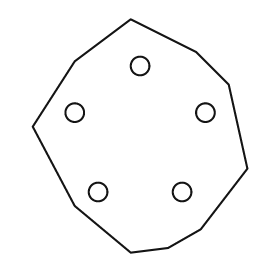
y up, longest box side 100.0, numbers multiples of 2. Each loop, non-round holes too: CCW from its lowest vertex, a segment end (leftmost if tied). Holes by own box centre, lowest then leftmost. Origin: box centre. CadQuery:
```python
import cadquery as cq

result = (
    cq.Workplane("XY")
    .moveTo(-4.0, -50.0)
    .lineTo(12.0, -48.0)
    .lineTo(26.0, -40.0)
    .lineTo(46.0, -14.0)
    .lineTo(38.0, 22.0)
    .lineTo(24.0, 36.0)
    .lineTo(-4.0, 50.0)
    .lineTo(-28.0, 32.0)
    .lineTo(-46.0, 4.0)
    .lineTo(-28.0, -30.0)
    .close()
    .moveTo(-18.0, -24.0)
    .circle(4.0)
    .moveTo(18.0, -24.0)
    .circle(4.0)
    .moveTo(-28.0, 10.0)
    .circle(4.0)
    .moveTo(28.0, 10.0)
    .circle(4.0)
    .moveTo(0.0, 30.0)
    .circle(4.0)
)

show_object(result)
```